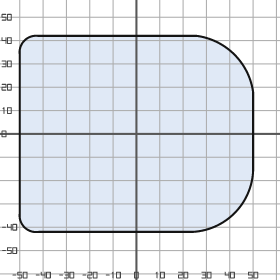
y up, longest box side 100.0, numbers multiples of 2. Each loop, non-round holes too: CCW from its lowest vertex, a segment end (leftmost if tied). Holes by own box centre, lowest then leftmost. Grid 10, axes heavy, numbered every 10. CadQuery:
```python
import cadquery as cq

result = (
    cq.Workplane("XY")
    .moveTo(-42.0, -42.0)
    .lineTo(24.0, -42.0)
    .threePointArc((42.0, -34.0), (50.0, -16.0))
    .lineTo(50.0, 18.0)
    .threePointArc((42.0, 34.0), (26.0, 42.0))
    .lineTo(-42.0, 42.0)
    .threePointArc((-48.0, 40.0), (-50.0, 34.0))
    .lineTo(-50.0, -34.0)
    .threePointArc((-48.0, -40.0), (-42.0, -42.0))
    .close()
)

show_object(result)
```